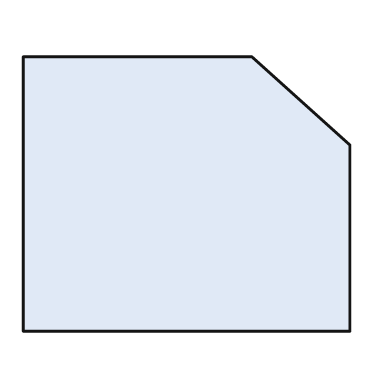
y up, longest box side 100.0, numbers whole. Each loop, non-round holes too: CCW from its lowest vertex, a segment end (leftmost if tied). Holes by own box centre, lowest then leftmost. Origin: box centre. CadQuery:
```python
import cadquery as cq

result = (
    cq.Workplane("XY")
    .moveTo(-50.0, -42.0)
    .lineTo(50.0, -42.0)
    .lineTo(50.0, 15.0)
    .lineTo(20.0, 42.0)
    .lineTo(-50.0, 42.0)
    .close()
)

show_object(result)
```